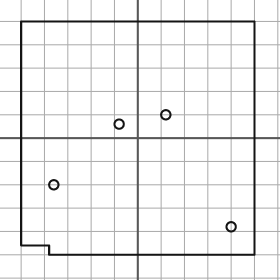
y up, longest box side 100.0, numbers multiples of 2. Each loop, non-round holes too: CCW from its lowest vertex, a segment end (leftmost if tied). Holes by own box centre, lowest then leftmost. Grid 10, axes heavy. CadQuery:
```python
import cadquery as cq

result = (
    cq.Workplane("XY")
    .moveTo(-38.0, -50.0)
    .lineTo(50.0, -50.0)
    .lineTo(50.0, 50.0)
    .lineTo(-50.0, 50.0)
    .lineTo(-50.0, -46.0)
    .lineTo(-38.0, -46.0)
    .close()
    .moveTo(40.0, -38.0)
    .circle(2.0)
    .moveTo(-36.0, -20.0)
    .circle(2.0)
    .moveTo(-8.0, 6.0)
    .circle(2.0)
    .moveTo(12.0, 10.0)
    .circle(2.0)
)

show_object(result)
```